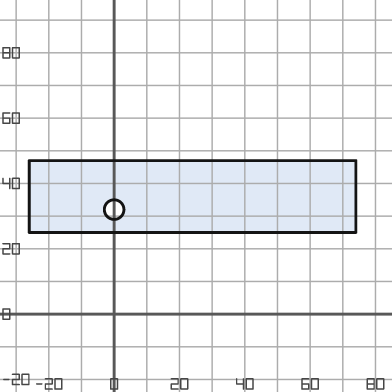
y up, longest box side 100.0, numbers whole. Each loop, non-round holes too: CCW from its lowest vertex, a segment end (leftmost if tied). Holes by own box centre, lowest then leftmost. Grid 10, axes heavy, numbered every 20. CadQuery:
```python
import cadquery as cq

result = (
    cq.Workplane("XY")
    .moveTo(-26.0, 25.0)
    .lineTo(74.0, 25.0)
    .lineTo(74.0, 47.0)
    .lineTo(-26.0, 47.0)
    .close()
    .moveTo(0.0, 32.0)
    .circle(3.0)
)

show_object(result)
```